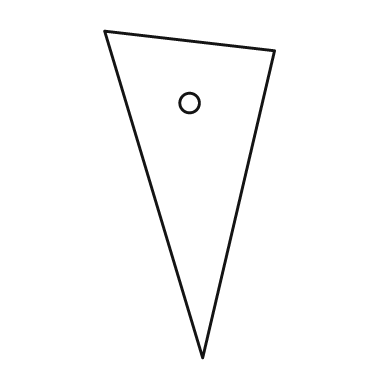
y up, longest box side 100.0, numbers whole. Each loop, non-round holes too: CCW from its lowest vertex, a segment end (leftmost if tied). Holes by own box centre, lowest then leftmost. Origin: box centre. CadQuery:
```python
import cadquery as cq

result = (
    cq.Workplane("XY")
    .moveTo(4.0, -50.0)
    .lineTo(26.0, 44.0)
    .lineTo(-26.0, 50.0)
    .close()
    .moveTo(0.0, 28.0)
    .circle(3.0)
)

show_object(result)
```